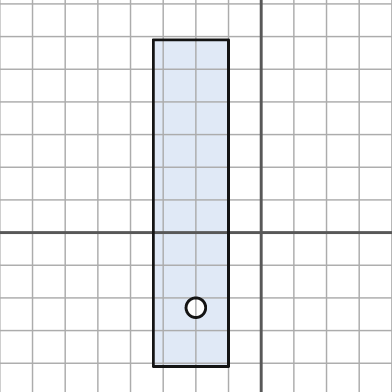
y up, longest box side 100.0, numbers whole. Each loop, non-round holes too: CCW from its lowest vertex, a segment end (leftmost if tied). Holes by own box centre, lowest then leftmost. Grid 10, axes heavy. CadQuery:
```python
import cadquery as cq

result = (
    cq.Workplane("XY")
    .moveTo(-33.0, -41.0)
    .lineTo(-10.0, -41.0)
    .lineTo(-10.0, 59.0)
    .lineTo(-33.0, 59.0)
    .close()
    .moveTo(-20.0, -23.0)
    .circle(3.0)
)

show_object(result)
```